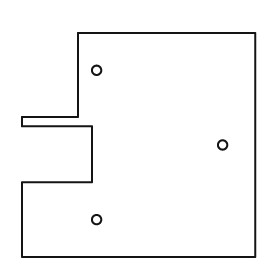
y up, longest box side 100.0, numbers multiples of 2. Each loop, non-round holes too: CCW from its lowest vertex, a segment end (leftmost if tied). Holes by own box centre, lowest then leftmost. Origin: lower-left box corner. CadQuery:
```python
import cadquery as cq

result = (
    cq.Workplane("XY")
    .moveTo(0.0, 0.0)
    .lineTo(100.0, 0.0)
    .lineTo(100.0, 96.0)
    .lineTo(24.0, 96.0)
    .lineTo(24.0, 60.0)
    .lineTo(0.0, 60.0)
    .lineTo(0.0, 56.0)
    .lineTo(30.0, 56.0)
    .lineTo(30.0, 32.0)
    .lineTo(0.0, 32.0)
    .close()
    .moveTo(32.0, 16.0)
    .circle(2.0)
    .moveTo(86.0, 48.0)
    .circle(2.0)
    .moveTo(32.0, 80.0)
    .circle(2.0)
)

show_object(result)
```